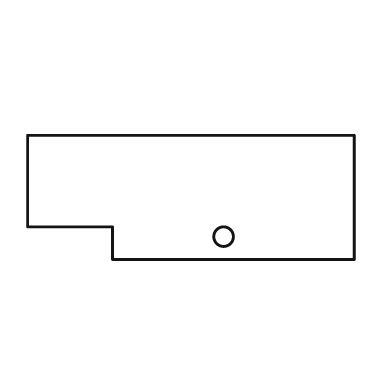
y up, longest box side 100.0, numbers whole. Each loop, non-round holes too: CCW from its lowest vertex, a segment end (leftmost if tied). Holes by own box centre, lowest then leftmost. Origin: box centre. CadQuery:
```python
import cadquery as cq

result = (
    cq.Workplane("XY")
    .moveTo(-24.0, -19.0)
    .lineTo(50.0, -19.0)
    .lineTo(50.0, 19.0)
    .lineTo(-50.0, 19.0)
    .lineTo(-50.0, -9.0)
    .lineTo(-24.0, -9.0)
    .close()
    .moveTo(10.0, -12.0)
    .circle(3.0)
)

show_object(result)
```